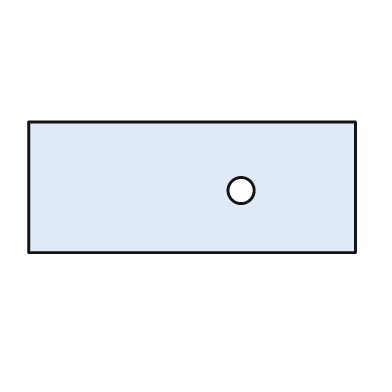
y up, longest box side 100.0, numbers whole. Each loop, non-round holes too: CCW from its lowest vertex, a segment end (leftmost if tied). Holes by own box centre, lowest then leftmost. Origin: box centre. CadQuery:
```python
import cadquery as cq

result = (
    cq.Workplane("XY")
    .moveTo(-50.0, -20.0)
    .lineTo(50.0, -20.0)
    .lineTo(50.0, 20.0)
    .lineTo(-50.0, 20.0)
    .close()
    .moveTo(15.0, -1.0)
    .circle(4.0)
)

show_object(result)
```